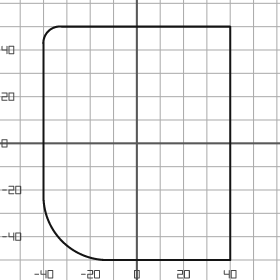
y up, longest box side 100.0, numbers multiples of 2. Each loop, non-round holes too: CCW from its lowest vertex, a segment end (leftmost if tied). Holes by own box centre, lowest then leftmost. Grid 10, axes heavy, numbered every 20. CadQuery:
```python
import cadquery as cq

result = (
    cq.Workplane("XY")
    .moveTo(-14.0, -50.0)
    .lineTo(40.0, -50.0)
    .lineTo(40.0, 50.0)
    .lineTo(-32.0, 50.0)
    .threePointArc((-38.0, 48.0), (-40.0, 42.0))
    .lineTo(-40.0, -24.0)
    .threePointArc((-32.0, -42.0), (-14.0, -50.0))
    .close()
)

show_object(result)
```